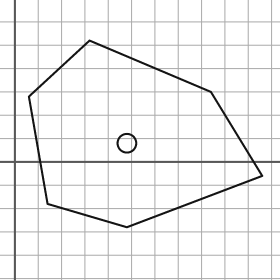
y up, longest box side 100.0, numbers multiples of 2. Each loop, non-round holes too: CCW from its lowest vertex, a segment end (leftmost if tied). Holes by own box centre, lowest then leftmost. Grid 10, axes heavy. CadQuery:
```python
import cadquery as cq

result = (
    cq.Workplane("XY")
    .moveTo(48.0, -28.0)
    .lineTo(106.0, -6.0)
    .lineTo(84.0, 30.0)
    .lineTo(32.0, 52.0)
    .lineTo(6.0, 28.0)
    .lineTo(14.0, -18.0)
    .close()
    .moveTo(48.0, 8.0)
    .circle(4.0)
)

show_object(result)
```